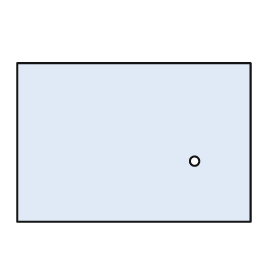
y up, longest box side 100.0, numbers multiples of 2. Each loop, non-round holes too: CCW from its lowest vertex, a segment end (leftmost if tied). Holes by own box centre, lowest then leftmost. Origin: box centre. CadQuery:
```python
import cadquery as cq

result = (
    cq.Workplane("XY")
    .moveTo(-50.0, -34.0)
    .lineTo(50.0, -34.0)
    .lineTo(50.0, 34.0)
    .lineTo(-50.0, 34.0)
    .close()
    .moveTo(26.0, -8.0)
    .circle(2.0)
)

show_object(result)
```